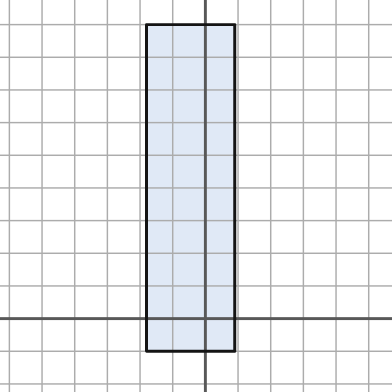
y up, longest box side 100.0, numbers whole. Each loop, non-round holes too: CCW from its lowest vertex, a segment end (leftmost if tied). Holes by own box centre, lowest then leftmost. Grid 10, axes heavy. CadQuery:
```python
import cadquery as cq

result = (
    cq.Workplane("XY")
    .moveTo(-18.0, -10.0)
    .lineTo(9.0, -10.0)
    .lineTo(9.0, 90.0)
    .lineTo(-18.0, 90.0)
    .close()
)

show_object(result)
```